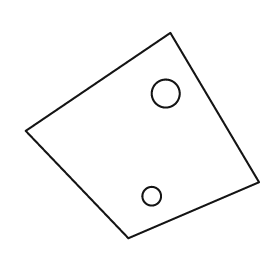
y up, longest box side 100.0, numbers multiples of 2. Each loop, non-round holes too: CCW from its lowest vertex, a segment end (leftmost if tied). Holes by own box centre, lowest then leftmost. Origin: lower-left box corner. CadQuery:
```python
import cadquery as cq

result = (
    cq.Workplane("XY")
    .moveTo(44.0, 0.0)
    .lineTo(100.0, 24.0)
    .lineTo(62.0, 88.0)
    .lineTo(0.0, 46.0)
    .close()
    .moveTo(54.0, 18.0)
    .circle(4.0)
    .moveTo(60.0, 62.0)
    .circle(6.0)
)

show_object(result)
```